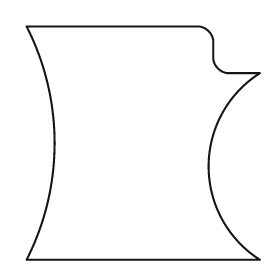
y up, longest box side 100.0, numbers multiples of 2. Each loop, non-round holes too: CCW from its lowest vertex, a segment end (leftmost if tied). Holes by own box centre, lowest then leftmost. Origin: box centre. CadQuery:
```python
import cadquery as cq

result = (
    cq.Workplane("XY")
    .moveTo(-50.0, -50.0)
    .lineTo(50.0, -50.0)
    .threePointArc((28.0, -10.0), (50.0, 30.0))
    .lineTo(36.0, 30.0)
    .threePointArc((32.0, 32.0), (30.0, 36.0))
    .lineTo(30.0, 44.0)
    .threePointArc((28.0, 48.0), (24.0, 50.0))
    .lineTo(-50.0, 50.0)
    .threePointArc((-38.0, 0.0), (-50.0, -50.0))
    .close()
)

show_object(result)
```